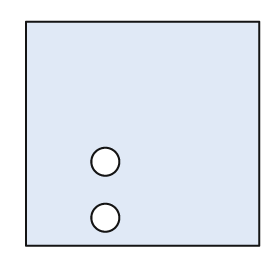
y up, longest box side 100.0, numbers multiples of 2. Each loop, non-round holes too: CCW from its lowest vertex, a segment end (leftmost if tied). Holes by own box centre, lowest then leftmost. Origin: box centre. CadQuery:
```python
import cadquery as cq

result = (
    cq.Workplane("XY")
    .moveTo(-50.0, -48.0)
    .lineTo(50.0, -48.0)
    .lineTo(50.0, 48.0)
    .lineTo(-50.0, 48.0)
    .close()
    .moveTo(-16.0, -36.0)
    .circle(6.0)
    .moveTo(-16.0, -12.0)
    .circle(6.0)
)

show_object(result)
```